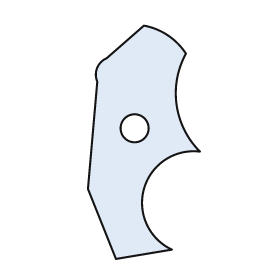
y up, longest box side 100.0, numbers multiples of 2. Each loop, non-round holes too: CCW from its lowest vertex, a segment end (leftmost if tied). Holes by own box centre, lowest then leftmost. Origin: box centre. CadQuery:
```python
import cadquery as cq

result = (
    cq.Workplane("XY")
    .moveTo(-12.0, -50.0)
    .lineTo(12.0, -46.0)
    .threePointArc((0.0, -20.0), (24.0, -4.0))
    .threePointArc((14.0, 16.0), (18.0, 38.0))
    .threePointArc((10.0, 46.0), (0.0, 50.0))
    .lineTo(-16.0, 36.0)
    .threePointArc((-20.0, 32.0), (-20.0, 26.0))
    .lineTo(-24.0, -20.0)
    .close()
    .moveTo(-4.0, 6.0)
    .circle(6.0)
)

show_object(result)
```